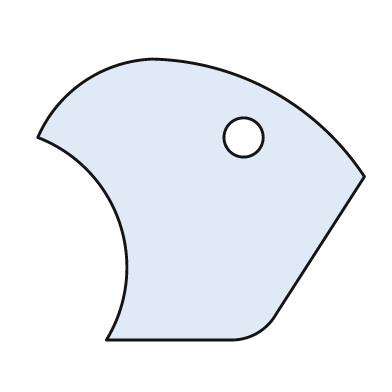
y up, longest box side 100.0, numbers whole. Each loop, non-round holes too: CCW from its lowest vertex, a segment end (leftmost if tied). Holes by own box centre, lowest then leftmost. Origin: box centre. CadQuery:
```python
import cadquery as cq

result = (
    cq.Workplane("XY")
    .moveTo(-29.0, -43.0)
    .lineTo(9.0, -43.0)
    .threePointArc((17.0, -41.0), (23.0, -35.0))
    .lineTo(50.0, 7.0)
    .threePointArc((22.0, 33.0), (-15.0, 43.0))
    .threePointArc((-36.0, 36.0), (-50.0, 19.0))
    .threePointArc((-25.0, -7.0), (-29.0, -43.0))
    .close()
    .moveTo(13.0, 19.0)
    .circle(6.0)
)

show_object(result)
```